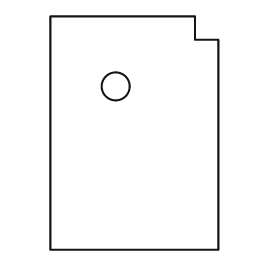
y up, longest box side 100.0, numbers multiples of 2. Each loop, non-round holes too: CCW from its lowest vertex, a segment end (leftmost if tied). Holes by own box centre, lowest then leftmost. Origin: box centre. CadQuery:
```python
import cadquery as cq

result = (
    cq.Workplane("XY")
    .moveTo(-36.0, -50.0)
    .lineTo(36.0, -50.0)
    .lineTo(36.0, 40.0)
    .lineTo(26.0, 40.0)
    .lineTo(26.0, 50.0)
    .lineTo(-36.0, 50.0)
    .close()
    .moveTo(-8.0, 20.0)
    .circle(6.0)
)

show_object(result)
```